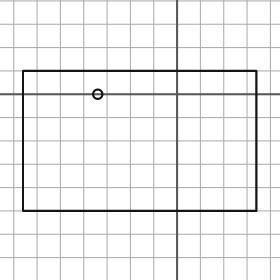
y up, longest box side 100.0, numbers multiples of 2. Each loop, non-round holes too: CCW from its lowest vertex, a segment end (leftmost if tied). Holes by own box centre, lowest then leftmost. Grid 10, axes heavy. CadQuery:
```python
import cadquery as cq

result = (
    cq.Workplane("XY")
    .moveTo(-66.0, -50.0)
    .lineTo(34.0, -50.0)
    .lineTo(34.0, 10.0)
    .lineTo(-66.0, 10.0)
    .close()
    .moveTo(-34.0, 0.0)
    .circle(2.0)
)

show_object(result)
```